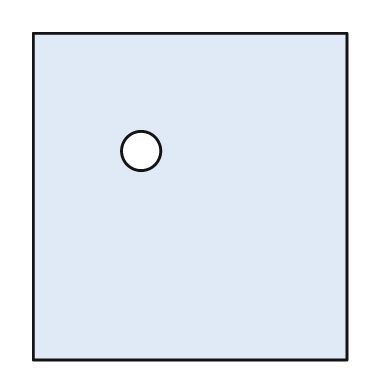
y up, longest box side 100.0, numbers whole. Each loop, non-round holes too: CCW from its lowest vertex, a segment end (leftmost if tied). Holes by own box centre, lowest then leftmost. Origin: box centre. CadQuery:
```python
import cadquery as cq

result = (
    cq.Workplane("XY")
    .moveTo(-48.0, -50.0)
    .lineTo(48.0, -50.0)
    .lineTo(48.0, 50.0)
    .lineTo(-48.0, 50.0)
    .close()
    .moveTo(-15.0, 14.0)
    .circle(6.0)
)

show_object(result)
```